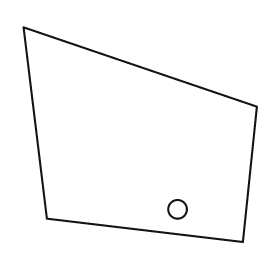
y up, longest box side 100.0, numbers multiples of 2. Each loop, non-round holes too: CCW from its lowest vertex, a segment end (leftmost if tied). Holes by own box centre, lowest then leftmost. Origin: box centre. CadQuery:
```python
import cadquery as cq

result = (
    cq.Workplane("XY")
    .moveTo(44.0, -46.0)
    .lineTo(50.0, 12.0)
    .lineTo(-50.0, 46.0)
    .lineTo(-40.0, -36.0)
    .close()
    .moveTo(16.0, -32.0)
    .circle(4.0)
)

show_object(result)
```